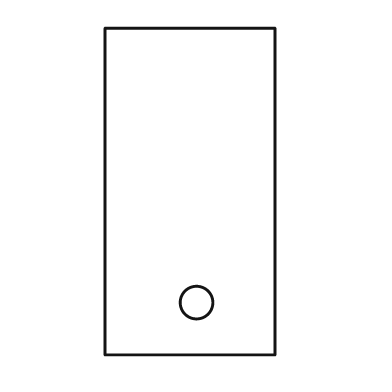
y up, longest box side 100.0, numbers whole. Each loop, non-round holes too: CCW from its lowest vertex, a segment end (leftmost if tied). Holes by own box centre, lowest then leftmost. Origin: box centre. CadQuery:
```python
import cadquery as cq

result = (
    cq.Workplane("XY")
    .moveTo(-26.0, -50.0)
    .lineTo(26.0, -50.0)
    .lineTo(26.0, 50.0)
    .lineTo(-26.0, 50.0)
    .close()
    .moveTo(2.0, -34.0)
    .circle(5.0)
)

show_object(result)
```